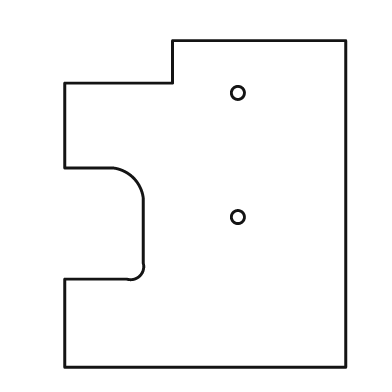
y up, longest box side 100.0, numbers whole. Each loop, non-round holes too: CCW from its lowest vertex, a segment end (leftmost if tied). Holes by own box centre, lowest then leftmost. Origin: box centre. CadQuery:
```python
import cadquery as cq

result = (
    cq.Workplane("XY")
    .moveTo(-43.0, -50.0)
    .lineTo(43.0, -50.0)
    .lineTo(43.0, 50.0)
    .lineTo(-10.0, 50.0)
    .lineTo(-10.0, 37.0)
    .lineTo(-43.0, 37.0)
    .lineTo(-43.0, 11.0)
    .lineTo(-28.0, 11.0)
    .threePointArc((-22.0, 8.0), (-19.0, 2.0))
    .lineTo(-19.0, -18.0)
    .threePointArc((-20.0, -22.0), (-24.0, -23.0))
    .lineTo(-43.0, -23.0)
    .close()
    .moveTo(10.0, -4.0)
    .circle(2.0)
    .moveTo(10.0, 34.0)
    .circle(2.0)
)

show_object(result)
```